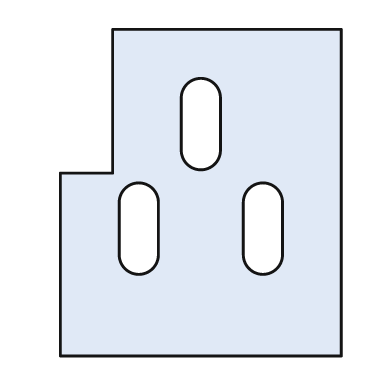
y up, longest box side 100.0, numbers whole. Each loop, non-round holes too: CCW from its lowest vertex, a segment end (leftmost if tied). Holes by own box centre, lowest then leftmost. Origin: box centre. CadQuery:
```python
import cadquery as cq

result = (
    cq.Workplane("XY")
    .moveTo(-43.0, -50.0)
    .lineTo(43.0, -50.0)
    .lineTo(43.0, 50.0)
    .lineTo(-27.0, 50.0)
    .lineTo(-27.0, 6.0)
    .lineTo(-43.0, 6.0)
    .close()
    .moveTo(-25.0, -19.0)
    .threePointArc((-19.0, -25.0), (-13.0, -19.0))
    .lineTo(-13.0, -3.0)
    .threePointArc((-19.0, 3.0), (-25.0, -3.0))
    .close()
    .moveTo(13.0, -19.0)
    .threePointArc((19.0, -25.0), (25.0, -19.0))
    .lineTo(25.0, -3.0)
    .threePointArc((19.0, 3.0), (13.0, -3.0))
    .close()
    .moveTo(-6.0, 13.0)
    .threePointArc((0.0, 7.0), (6.0, 13.0))
    .lineTo(6.0, 29.0)
    .threePointArc((0.0, 35.0), (-6.0, 29.0))
    .close()
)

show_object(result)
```